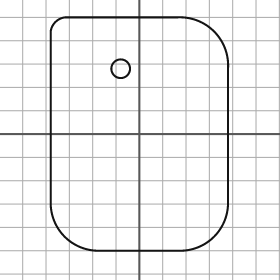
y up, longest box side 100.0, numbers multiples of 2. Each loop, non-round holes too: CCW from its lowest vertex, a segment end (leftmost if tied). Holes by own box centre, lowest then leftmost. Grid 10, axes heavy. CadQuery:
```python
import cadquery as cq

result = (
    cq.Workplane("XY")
    .moveTo(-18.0, -50.0)
    .lineTo(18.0, -50.0)
    .threePointArc((32.0, -44.0), (38.0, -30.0))
    .lineTo(38.0, 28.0)
    .threePointArc((32.0, 44.0), (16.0, 50.0))
    .lineTo(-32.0, 50.0)
    .threePointArc((-36.0, 48.0), (-38.0, 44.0))
    .lineTo(-38.0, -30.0)
    .threePointArc((-32.0, -44.0), (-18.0, -50.0))
    .close()
    .moveTo(-8.0, 28.0)
    .circle(4.0)
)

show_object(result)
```